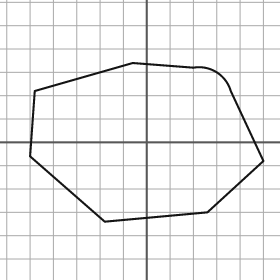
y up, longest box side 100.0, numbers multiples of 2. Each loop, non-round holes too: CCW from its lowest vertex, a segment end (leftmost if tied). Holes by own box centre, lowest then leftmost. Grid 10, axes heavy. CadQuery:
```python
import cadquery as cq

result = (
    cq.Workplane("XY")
    .moveTo(-18.0, -34.0)
    .lineTo(26.0, -30.0)
    .lineTo(50.0, -8.0)
    .lineTo(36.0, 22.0)
    .threePointArc((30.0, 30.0), (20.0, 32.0))
    .lineTo(-6.0, 34.0)
    .lineTo(-48.0, 22.0)
    .lineTo(-50.0, -6.0)
    .close()
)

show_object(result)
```